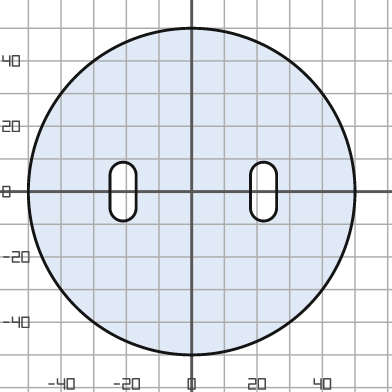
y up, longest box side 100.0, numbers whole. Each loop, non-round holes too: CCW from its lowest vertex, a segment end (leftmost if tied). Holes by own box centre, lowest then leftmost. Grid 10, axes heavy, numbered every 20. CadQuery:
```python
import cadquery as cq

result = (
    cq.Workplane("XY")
    .moveTo(0.0, 0.0)
    .circle(50.0)
    .moveTo(-25.0, -5.0)
    .threePointArc((-21.0, -9.0), (-17.0, -5.0))
    .lineTo(-17.0, 5.0)
    .threePointArc((-21.0, 9.0), (-25.0, 5.0))
    .close()
    .moveTo(18.0, -5.0)
    .threePointArc((22.0, -9.0), (26.0, -5.0))
    .lineTo(26.0, 5.0)
    .threePointArc((22.0, 9.0), (18.0, 5.0))
    .close()
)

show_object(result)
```